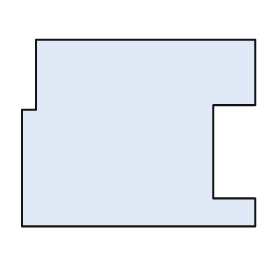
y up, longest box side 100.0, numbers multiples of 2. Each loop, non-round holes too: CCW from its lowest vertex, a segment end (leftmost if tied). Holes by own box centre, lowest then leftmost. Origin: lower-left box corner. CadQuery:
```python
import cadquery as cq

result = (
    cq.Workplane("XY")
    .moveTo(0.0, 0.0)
    .lineTo(100.0, 0.0)
    .lineTo(100.0, 12.0)
    .lineTo(82.0, 12.0)
    .lineTo(82.0, 52.0)
    .lineTo(100.0, 52.0)
    .lineTo(100.0, 80.0)
    .lineTo(6.0, 80.0)
    .lineTo(6.0, 50.0)
    .lineTo(0.0, 50.0)
    .close()
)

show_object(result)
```